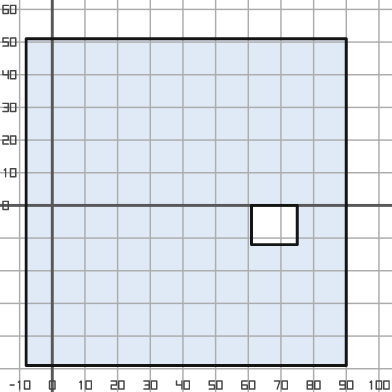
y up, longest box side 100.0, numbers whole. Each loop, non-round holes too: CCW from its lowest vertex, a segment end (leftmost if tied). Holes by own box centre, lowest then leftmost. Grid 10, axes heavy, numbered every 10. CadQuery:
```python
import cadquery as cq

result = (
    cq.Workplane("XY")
    .moveTo(-8.0, -49.0)
    .lineTo(90.0, -49.0)
    .lineTo(90.0, 51.0)
    .lineTo(-8.0, 51.0)
    .close()
    .moveTo(61.0, -12.0)
    .lineTo(75.0, -12.0)
    .lineTo(75.0, 0.0)
    .lineTo(61.0, 0.0)
    .close()
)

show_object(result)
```